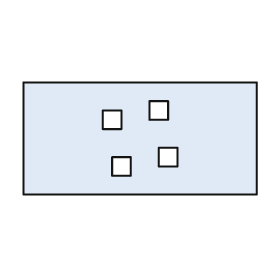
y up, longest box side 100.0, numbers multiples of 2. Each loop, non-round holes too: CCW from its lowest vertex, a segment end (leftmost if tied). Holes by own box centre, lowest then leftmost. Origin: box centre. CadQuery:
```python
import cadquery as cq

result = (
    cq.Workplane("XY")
    .moveTo(-50.0, -24.0)
    .lineTo(50.0, -24.0)
    .lineTo(50.0, 24.0)
    .lineTo(-50.0, 24.0)
    .close()
    .moveTo(-12.0, -16.0)
    .lineTo(-4.0, -16.0)
    .lineTo(-4.0, -8.0)
    .lineTo(-12.0, -8.0)
    .close()
    .moveTo(8.0, -12.0)
    .lineTo(16.0, -12.0)
    .lineTo(16.0, -4.0)
    .lineTo(8.0, -4.0)
    .close()
    .moveTo(-16.0, 4.0)
    .lineTo(-8.0, 4.0)
    .lineTo(-8.0, 12.0)
    .lineTo(-16.0, 12.0)
    .close()
    .moveTo(4.0, 8.0)
    .lineTo(12.0, 8.0)
    .lineTo(12.0, 16.0)
    .lineTo(4.0, 16.0)
    .close()
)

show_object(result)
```